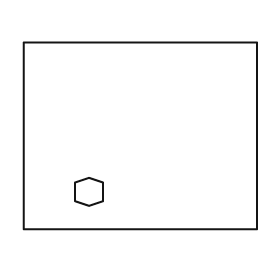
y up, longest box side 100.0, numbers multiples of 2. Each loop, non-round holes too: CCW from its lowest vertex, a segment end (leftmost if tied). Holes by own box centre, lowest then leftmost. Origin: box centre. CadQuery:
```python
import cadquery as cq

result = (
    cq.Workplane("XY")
    .moveTo(-50.0, -40.0)
    .lineTo(50.0, -40.0)
    .lineTo(50.0, 40.0)
    .lineTo(-50.0, 40.0)
    .close()
    .moveTo(-22.0, -30.0)
    .lineTo(-16.0, -28.0)
    .lineTo(-16.0, -20.0)
    .lineTo(-22.0, -18.0)
    .lineTo(-28.0, -20.0)
    .lineTo(-28.0, -28.0)
    .close()
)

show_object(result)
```